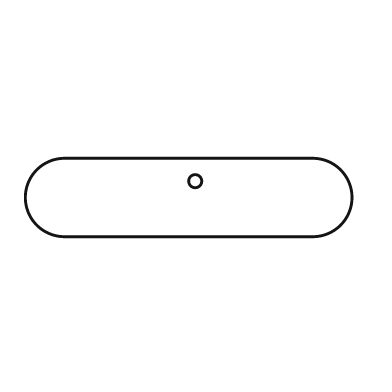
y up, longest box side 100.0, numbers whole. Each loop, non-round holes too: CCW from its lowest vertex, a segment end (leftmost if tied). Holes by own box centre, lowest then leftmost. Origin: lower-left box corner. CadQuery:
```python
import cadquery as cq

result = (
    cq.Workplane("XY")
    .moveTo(12.0, 0.0)
    .lineTo(88.0, 0.0)
    .threePointArc((100.0, 12.0), (88.0, 24.0))
    .lineTo(12.0, 24.0)
    .threePointArc((0.0, 12.0), (12.0, 0.0))
    .close()
    .moveTo(52.0, 17.0)
    .circle(2.0)
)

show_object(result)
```